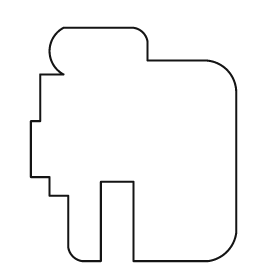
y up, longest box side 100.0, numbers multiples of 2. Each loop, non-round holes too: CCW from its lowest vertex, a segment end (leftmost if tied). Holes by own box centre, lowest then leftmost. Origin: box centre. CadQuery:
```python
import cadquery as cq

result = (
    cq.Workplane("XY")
    .moveTo(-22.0, -50.0)
    .lineTo(-14.0, -50.0)
    .lineTo(-14.0, -16.0)
    .lineTo(0.0, -16.0)
    .lineTo(0.0, -50.0)
    .lineTo(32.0, -50.0)
    .threePointArc((40.0, -46.0), (44.0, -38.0))
    .lineTo(44.0, 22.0)
    .threePointArc((40.0, 32.0), (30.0, 36.0))
    .lineTo(6.0, 36.0)
    .lineTo(6.0, 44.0)
    .threePointArc((4.0, 48.0), (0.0, 50.0))
    .lineTo(-30.0, 50.0)
    .threePointArc((-36.0, 40.0), (-30.0, 30.0))
    .lineTo(-40.0, 30.0)
    .lineTo(-40.0, 10.0)
    .lineTo(-44.0, 10.0)
    .lineTo(-44.0, -14.0)
    .lineTo(-36.0, -14.0)
    .lineTo(-36.0, -22.0)
    .lineTo(-28.0, -22.0)
    .lineTo(-28.0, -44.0)
    .threePointArc((-26.0, -48.0), (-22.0, -50.0))
    .close()
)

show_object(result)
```